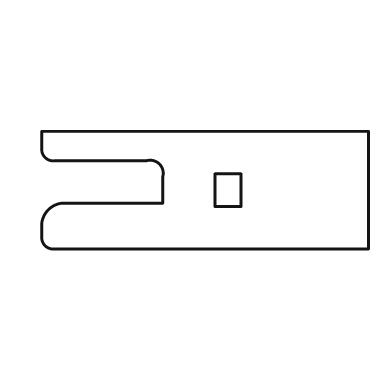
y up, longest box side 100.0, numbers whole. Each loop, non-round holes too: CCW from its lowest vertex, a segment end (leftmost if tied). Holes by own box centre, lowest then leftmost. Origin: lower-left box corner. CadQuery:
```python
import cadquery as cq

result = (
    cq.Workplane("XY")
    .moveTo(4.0, 0.0)
    .lineTo(100.0, 0.0)
    .lineTo(100.0, 36.0)
    .lineTo(0.0, 36.0)
    .lineTo(0.0, 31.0)
    .threePointArc((1.0, 28.0), (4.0, 27.0))
    .lineTo(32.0, 27.0)
    .threePointArc((36.0, 26.0), (37.0, 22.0))
    .lineTo(37.0, 14.0)
    .lineTo(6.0, 14.0)
    .threePointArc((2.0, 12.0), (0.0, 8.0))
    .lineTo(0.0, 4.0)
    .threePointArc((1.0, 1.0), (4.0, 0.0))
    .close()
    .moveTo(53.0, 13.0)
    .lineTo(61.0, 13.0)
    .lineTo(61.0, 23.0)
    .lineTo(53.0, 23.0)
    .close()
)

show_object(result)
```